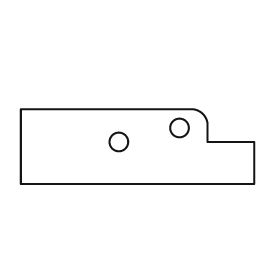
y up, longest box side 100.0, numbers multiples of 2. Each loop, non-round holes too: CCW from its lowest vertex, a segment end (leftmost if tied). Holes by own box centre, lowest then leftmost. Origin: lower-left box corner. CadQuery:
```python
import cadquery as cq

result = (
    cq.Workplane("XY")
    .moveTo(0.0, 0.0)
    .lineTo(100.0, 0.0)
    .lineTo(100.0, 18.0)
    .lineTo(80.0, 18.0)
    .lineTo(80.0, 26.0)
    .threePointArc((78.0, 30.0), (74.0, 32.0))
    .lineTo(0.0, 32.0)
    .close()
    .moveTo(42.0, 18.0)
    .circle(4.0)
    .moveTo(68.0, 24.0)
    .circle(4.0)
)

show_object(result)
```